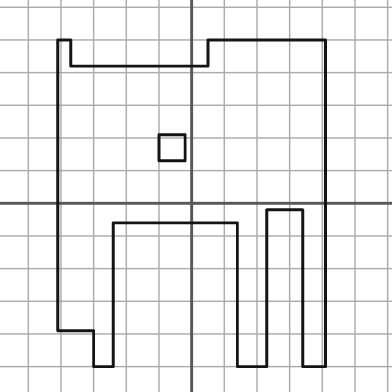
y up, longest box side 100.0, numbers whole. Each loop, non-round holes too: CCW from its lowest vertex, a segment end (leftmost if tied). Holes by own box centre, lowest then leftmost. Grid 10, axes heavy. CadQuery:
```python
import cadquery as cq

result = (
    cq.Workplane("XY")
    .moveTo(-30.0, -50.0)
    .lineTo(-24.0, -50.0)
    .lineTo(-24.0, -6.0)
    .lineTo(14.0, -6.0)
    .lineTo(14.0, -50.0)
    .lineTo(23.0, -50.0)
    .lineTo(23.0, -2.0)
    .lineTo(34.0, -2.0)
    .lineTo(34.0, -50.0)
    .lineTo(41.0, -50.0)
    .lineTo(41.0, 50.0)
    .lineTo(5.0, 50.0)
    .lineTo(5.0, 42.0)
    .lineTo(-37.0, 42.0)
    .lineTo(-37.0, 50.0)
    .lineTo(-41.0, 50.0)
    .lineTo(-41.0, -39.0)
    .lineTo(-30.0, -39.0)
    .close()
    .moveTo(-10.0, 13.0)
    .lineTo(-2.0, 13.0)
    .lineTo(-2.0, 21.0)
    .lineTo(-10.0, 21.0)
    .close()
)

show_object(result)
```